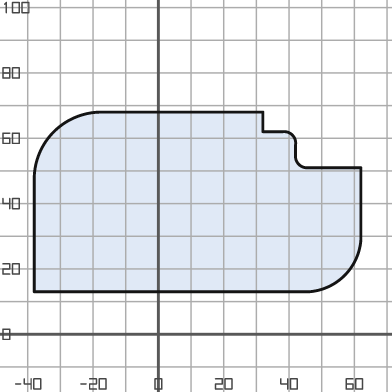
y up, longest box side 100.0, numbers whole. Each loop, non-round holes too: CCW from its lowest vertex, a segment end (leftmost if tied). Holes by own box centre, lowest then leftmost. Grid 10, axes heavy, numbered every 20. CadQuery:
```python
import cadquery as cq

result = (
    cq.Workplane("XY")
    .moveTo(-38.0, 13.0)
    .lineTo(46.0, 13.0)
    .threePointArc((57.0, 18.0), (62.0, 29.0))
    .lineTo(62.0, 51.0)
    .lineTo(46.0, 51.0)
    .threePointArc((43.0, 52.0), (42.0, 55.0))
    .lineTo(42.0, 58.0)
    .threePointArc((41.0, 61.0), (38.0, 62.0))
    .lineTo(32.0, 62.0)
    .lineTo(32.0, 68.0)
    .lineTo(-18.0, 68.0)
    .threePointArc((-32.0, 62.0), (-38.0, 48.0))
    .close()
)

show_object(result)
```